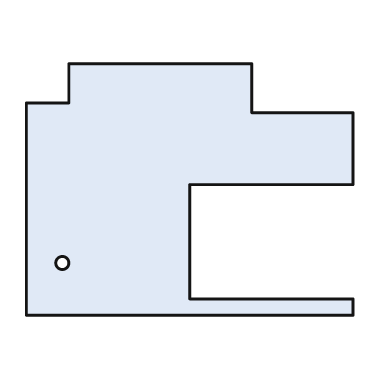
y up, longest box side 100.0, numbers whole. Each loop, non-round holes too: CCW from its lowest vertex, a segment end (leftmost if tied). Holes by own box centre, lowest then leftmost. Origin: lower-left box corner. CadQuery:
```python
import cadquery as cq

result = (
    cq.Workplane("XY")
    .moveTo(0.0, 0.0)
    .lineTo(100.0, 0.0)
    .lineTo(100.0, 5.0)
    .lineTo(50.0, 5.0)
    .lineTo(50.0, 40.0)
    .lineTo(100.0, 40.0)
    .lineTo(100.0, 62.0)
    .lineTo(69.0, 62.0)
    .lineTo(69.0, 77.0)
    .lineTo(13.0, 77.0)
    .lineTo(13.0, 65.0)
    .lineTo(0.0, 65.0)
    .close()
    .moveTo(11.0, 16.0)
    .circle(2.0)
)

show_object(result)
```